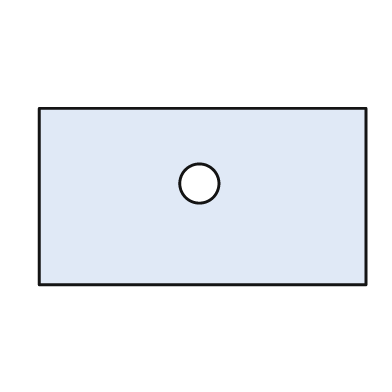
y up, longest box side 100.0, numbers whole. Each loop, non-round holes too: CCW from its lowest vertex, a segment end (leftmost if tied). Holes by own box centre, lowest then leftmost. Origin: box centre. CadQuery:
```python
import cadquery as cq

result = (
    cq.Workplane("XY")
    .moveTo(-50.0, -27.0)
    .lineTo(50.0, -27.0)
    .lineTo(50.0, 27.0)
    .lineTo(-50.0, 27.0)
    .close()
    .moveTo(-1.0, 4.0)
    .circle(6.0)
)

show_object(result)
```